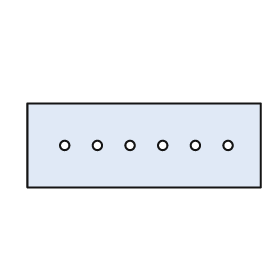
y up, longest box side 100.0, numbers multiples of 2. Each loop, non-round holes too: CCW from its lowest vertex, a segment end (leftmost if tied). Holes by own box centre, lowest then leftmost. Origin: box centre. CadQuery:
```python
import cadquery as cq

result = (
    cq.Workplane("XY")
    .moveTo(-50.0, -18.0)
    .lineTo(50.0, -18.0)
    .lineTo(50.0, 18.0)
    .lineTo(-50.0, 18.0)
    .close()
    .moveTo(-34.0, 0.0)
    .circle(2.0)
    .moveTo(-20.0, 0.0)
    .circle(2.0)
    .moveTo(-6.0, 0.0)
    .circle(2.0)
    .moveTo(8.0, 0.0)
    .circle(2.0)
    .moveTo(22.0, 0.0)
    .circle(2.0)
    .moveTo(36.0, 0.0)
    .circle(2.0)
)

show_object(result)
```